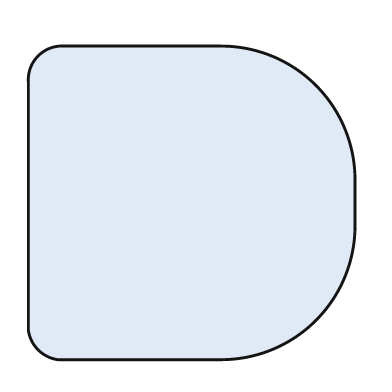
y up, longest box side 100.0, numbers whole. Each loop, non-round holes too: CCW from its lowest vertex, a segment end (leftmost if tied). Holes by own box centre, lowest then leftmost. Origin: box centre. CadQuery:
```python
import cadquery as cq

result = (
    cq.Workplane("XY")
    .moveTo(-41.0, -48.0)
    .lineTo(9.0, -48.0)
    .threePointArc((38.0, -36.0), (50.0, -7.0))
    .lineTo(50.0, 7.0)
    .threePointArc((38.0, 36.0), (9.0, 48.0))
    .lineTo(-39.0, 48.0)
    .threePointArc((-47.0, 45.0), (-50.0, 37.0))
    .lineTo(-50.0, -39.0)
    .threePointArc((-47.0, -45.0), (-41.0, -48.0))
    .close()
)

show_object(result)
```